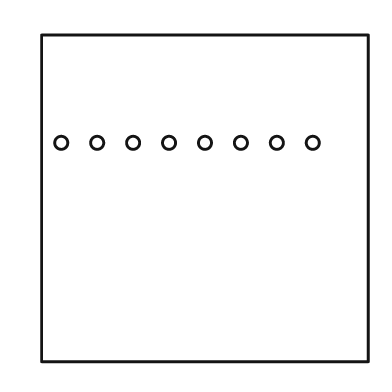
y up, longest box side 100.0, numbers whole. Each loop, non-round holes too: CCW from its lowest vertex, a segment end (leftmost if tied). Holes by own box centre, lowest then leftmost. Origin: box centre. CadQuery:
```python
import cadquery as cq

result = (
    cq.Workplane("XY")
    .moveTo(-50.0, -50.0)
    .lineTo(50.0, -50.0)
    .lineTo(50.0, 50.0)
    .lineTo(-50.0, 50.0)
    .close()
    .moveTo(-44.0, 17.0)
    .circle(2.0)
    .moveTo(-33.0, 17.0)
    .circle(2.0)
    .moveTo(-22.0, 17.0)
    .circle(2.0)
    .moveTo(-11.0, 17.0)
    .circle(2.0)
    .moveTo(0.0, 17.0)
    .circle(2.0)
    .moveTo(11.0, 17.0)
    .circle(2.0)
    .moveTo(22.0, 17.0)
    .circle(2.0)
    .moveTo(33.0, 17.0)
    .circle(2.0)
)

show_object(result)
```